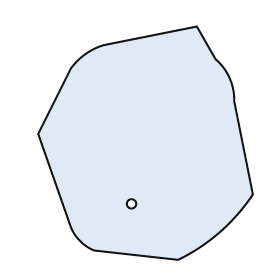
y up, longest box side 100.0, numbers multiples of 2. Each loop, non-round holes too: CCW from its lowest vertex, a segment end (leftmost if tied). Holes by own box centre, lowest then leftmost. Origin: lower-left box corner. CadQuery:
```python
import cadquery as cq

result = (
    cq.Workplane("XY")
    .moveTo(60.0, 0.0)
    .threePointArc((78.0, 12.0), (92.0, 28.0))
    .lineTo(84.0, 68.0)
    .threePointArc((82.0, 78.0), (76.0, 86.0))
    .lineTo(68.0, 100.0)
    .lineTo(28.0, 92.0)
    .threePointArc((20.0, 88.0), (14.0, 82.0))
    .lineTo(0.0, 54.0)
    .lineTo(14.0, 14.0)
    .threePointArc((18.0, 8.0), (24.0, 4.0))
    .close()
    .moveTo(40.0, 24.0)
    .circle(2.0)
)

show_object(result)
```